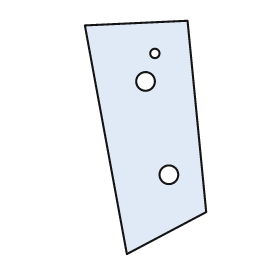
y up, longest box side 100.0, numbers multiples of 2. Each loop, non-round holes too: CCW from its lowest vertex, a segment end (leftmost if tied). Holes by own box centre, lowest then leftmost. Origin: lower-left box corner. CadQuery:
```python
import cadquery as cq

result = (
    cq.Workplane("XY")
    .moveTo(18.0, 0.0)
    .lineTo(52.0, 18.0)
    .lineTo(44.0, 100.0)
    .lineTo(0.0, 98.0)
    .close()
    .moveTo(36.0, 34.0)
    .circle(4.0)
    .moveTo(26.0, 74.0)
    .circle(4.0)
    .moveTo(30.0, 86.0)
    .circle(2.0)
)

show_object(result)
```